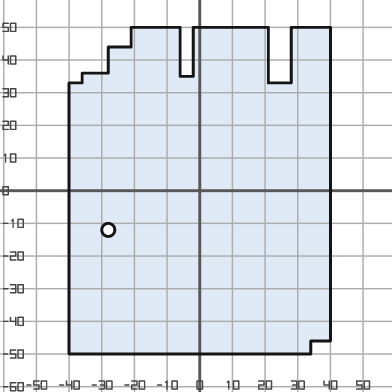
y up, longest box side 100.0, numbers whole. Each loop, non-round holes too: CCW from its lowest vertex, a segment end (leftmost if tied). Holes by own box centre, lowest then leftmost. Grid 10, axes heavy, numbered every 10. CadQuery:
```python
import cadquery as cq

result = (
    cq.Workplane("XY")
    .moveTo(-40.0, -50.0)
    .lineTo(34.0, -50.0)
    .lineTo(34.0, -46.0)
    .lineTo(40.0, -46.0)
    .lineTo(40.0, 50.0)
    .lineTo(28.0, 50.0)
    .lineTo(28.0, 33.0)
    .lineTo(21.0, 33.0)
    .lineTo(21.0, 50.0)
    .lineTo(-2.0, 50.0)
    .lineTo(-2.0, 35.0)
    .lineTo(-6.0, 35.0)
    .lineTo(-6.0, 50.0)
    .lineTo(-21.0, 50.0)
    .lineTo(-21.0, 44.0)
    .lineTo(-28.0, 44.0)
    .lineTo(-28.0, 36.0)
    .lineTo(-36.0, 36.0)
    .lineTo(-36.0, 33.0)
    .lineTo(-40.0, 33.0)
    .close()
    .moveTo(-28.0, -12.0)
    .circle(2.0)
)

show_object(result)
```